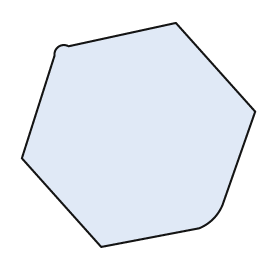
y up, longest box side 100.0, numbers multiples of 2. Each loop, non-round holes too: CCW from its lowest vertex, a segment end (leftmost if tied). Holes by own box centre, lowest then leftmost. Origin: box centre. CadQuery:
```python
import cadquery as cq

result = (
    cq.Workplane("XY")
    .moveTo(-16.0, -48.0)
    .lineTo(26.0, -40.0)
    .threePointArc((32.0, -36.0), (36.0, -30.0))
    .lineTo(50.0, 10.0)
    .lineTo(16.0, 48.0)
    .lineTo(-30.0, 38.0)
    .threePointArc((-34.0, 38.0), (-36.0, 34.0))
    .lineTo(-50.0, -10.0)
    .close()
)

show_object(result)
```